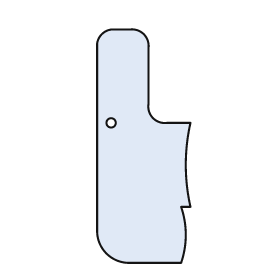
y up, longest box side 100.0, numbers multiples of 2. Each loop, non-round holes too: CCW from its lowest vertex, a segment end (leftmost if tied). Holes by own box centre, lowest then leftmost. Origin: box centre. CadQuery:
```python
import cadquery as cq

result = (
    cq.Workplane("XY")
    .moveTo(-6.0, -50.0)
    .lineTo(16.0, -50.0)
    .threePointArc((18.0, -38.0), (16.0, -26.0))
    .lineTo(20.0, -26.0)
    .threePointArc((18.0, -8.0), (20.0, 10.0))
    .lineTo(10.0, 10.0)
    .threePointArc((4.0, 12.0), (2.0, 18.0))
    .lineTo(2.0, 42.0)
    .threePointArc((0.0, 48.0), (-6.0, 50.0))
    .lineTo(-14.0, 50.0)
    .threePointArc((-18.0, 48.0), (-20.0, 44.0))
    .lineTo(-20.0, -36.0)
    .threePointArc((-16.0, -46.0), (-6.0, -50.0))
    .close()
    .moveTo(-14.0, 10.0)
    .circle(2.0)
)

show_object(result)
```